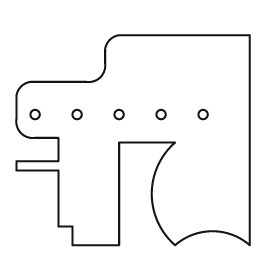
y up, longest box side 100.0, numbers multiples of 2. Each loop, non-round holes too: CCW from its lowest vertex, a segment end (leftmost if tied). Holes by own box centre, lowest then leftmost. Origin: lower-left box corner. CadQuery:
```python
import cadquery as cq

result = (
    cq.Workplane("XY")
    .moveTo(24.0, 0.0)
    .lineTo(44.0, 0.0)
    .lineTo(44.0, 44.0)
    .lineTo(68.0, 44.0)
    .threePointArc((58.0, 22.0), (68.0, 0.0))
    .threePointArc((84.0, 6.0), (100.0, 0.0))
    .lineTo(100.0, 90.0)
    .lineTo(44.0, 90.0)
    .threePointArc((40.0, 88.0), (38.0, 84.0))
    .lineTo(38.0, 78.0)
    .threePointArc((36.0, 72.0), (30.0, 70.0))
    .lineTo(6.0, 70.0)
    .threePointArc((2.0, 68.0), (0.0, 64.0))
    .lineTo(0.0, 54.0)
    .threePointArc((2.0, 48.0), (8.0, 46.0))
    .lineTo(18.0, 46.0)
    .lineTo(18.0, 36.0)
    .lineTo(0.0, 36.0)
    .lineTo(0.0, 32.0)
    .lineTo(18.0, 32.0)
    .lineTo(18.0, 8.0)
    .lineTo(24.0, 8.0)
    .close()
    .moveTo(8.0, 56.0)
    .circle(2.0)
    .moveTo(26.0, 56.0)
    .circle(2.0)
    .moveTo(44.0, 56.0)
    .circle(2.0)
    .moveTo(62.0, 56.0)
    .circle(2.0)
    .moveTo(80.0, 56.0)
    .circle(2.0)
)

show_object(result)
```